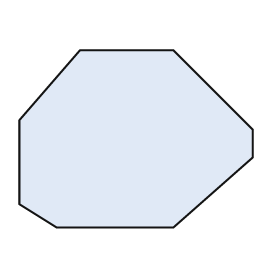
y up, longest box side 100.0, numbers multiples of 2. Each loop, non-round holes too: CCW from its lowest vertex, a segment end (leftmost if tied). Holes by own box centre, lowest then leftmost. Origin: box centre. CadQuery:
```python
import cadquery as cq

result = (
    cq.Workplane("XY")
    .moveTo(-34.0, -38.0)
    .lineTo(16.0, -38.0)
    .lineTo(50.0, -8.0)
    .lineTo(50.0, 4.0)
    .lineTo(16.0, 38.0)
    .lineTo(-24.0, 38.0)
    .lineTo(-50.0, 8.0)
    .lineTo(-50.0, -28.0)
    .close()
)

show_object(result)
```